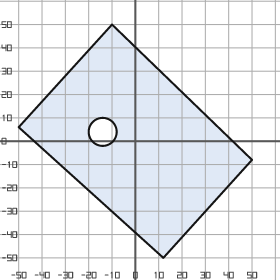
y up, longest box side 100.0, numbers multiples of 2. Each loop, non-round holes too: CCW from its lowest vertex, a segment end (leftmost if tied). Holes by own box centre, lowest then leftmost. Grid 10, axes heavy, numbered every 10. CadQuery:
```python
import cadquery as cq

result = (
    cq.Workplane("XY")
    .moveTo(12.0, -50.0)
    .lineTo(50.0, -8.0)
    .lineTo(-10.0, 50.0)
    .lineTo(-50.0, 6.0)
    .close()
    .moveTo(-14.0, 4.0)
    .circle(6.0)
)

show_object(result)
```